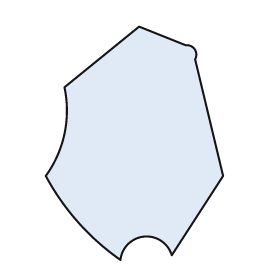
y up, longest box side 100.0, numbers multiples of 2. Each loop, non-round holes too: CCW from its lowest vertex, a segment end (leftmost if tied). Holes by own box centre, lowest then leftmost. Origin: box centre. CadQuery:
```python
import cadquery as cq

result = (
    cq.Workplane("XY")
    .moveTo(-6.0, -50.0)
    .threePointArc((4.0, -40.0), (16.0, -48.0))
    .lineTo(38.0, -14.0)
    .lineTo(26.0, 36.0)
    .threePointArc((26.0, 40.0), (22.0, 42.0))
    .lineTo(2.0, 50.0)
    .lineTo(-30.0, 24.0)
    .threePointArc((-30.0, 4.0), (-38.0, -14.0))
    .threePointArc((-24.0, -34.0), (-6.0, -50.0))
    .close()
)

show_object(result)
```